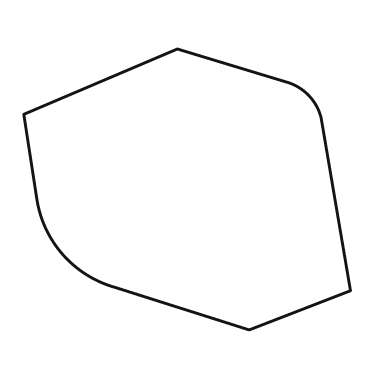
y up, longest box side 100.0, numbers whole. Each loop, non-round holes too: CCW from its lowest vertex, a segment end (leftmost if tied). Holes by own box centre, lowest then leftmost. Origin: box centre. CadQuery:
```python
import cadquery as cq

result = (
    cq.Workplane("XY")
    .moveTo(19.0, -43.0)
    .lineTo(50.0, -31.0)
    .lineTo(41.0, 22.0)
    .threePointArc((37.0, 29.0), (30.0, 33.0))
    .lineTo(-3.0, 43.0)
    .lineTo(-50.0, 23.0)
    .lineTo(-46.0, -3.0)
    .threePointArc((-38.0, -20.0), (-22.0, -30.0))
    .close()
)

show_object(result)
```